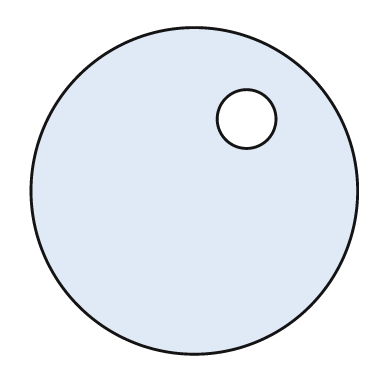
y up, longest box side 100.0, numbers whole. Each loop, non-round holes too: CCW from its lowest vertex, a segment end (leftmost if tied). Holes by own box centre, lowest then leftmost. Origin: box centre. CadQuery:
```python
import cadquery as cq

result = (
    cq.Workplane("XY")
    .moveTo(0.0, 0.0)
    .circle(50.0)
    .moveTo(16.0, 22.0)
    .circle(9.0)
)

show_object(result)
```